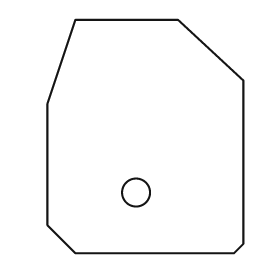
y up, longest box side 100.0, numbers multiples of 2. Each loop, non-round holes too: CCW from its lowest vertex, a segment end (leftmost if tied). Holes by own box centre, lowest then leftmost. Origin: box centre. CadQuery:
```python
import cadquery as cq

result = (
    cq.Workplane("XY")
    .moveTo(-30.0, -50.0)
    .lineTo(38.0, -50.0)
    .lineTo(42.0, -46.0)
    .lineTo(42.0, 24.0)
    .lineTo(14.0, 50.0)
    .lineTo(-30.0, 50.0)
    .lineTo(-42.0, 14.0)
    .lineTo(-42.0, -38.0)
    .close()
    .moveTo(-4.0, -24.0)
    .circle(6.0)
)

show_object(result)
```